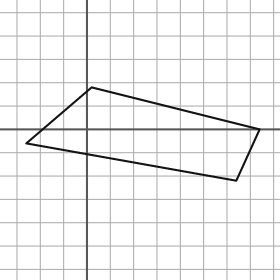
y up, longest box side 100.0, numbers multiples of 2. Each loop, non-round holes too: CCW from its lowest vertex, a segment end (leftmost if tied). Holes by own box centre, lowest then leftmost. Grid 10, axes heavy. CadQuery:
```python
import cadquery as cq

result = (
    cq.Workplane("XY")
    .moveTo(64.0, -22.0)
    .lineTo(74.0, 0.0)
    .lineTo(2.0, 18.0)
    .lineTo(-26.0, -6.0)
    .close()
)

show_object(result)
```